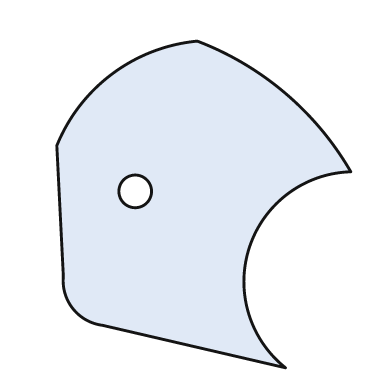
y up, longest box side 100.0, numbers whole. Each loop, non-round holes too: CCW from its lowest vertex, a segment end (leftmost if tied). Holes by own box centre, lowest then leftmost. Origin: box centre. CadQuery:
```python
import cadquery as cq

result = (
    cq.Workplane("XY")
    .moveTo(25.0, -50.0)
    .threePointArc((14.0, -13.0), (45.0, 10.0))
    .threePointArc((25.0, 34.0), (-2.0, 50.0))
    .threePointArc((-28.0, 40.0), (-45.0, 18.0))
    .lineTo(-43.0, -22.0)
    .threePointArc((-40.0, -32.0), (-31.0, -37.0))
    .close()
    .moveTo(-21.0, 4.0)
    .circle(5.0)
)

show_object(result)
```